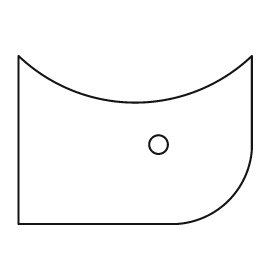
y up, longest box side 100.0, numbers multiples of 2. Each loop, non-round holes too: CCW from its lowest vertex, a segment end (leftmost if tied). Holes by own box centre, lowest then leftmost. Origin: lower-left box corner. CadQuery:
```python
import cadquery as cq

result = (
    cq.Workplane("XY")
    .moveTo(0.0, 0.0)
    .lineTo(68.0, 0.0)
    .threePointArc((90.0, 10.0), (100.0, 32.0))
    .lineTo(100.0, 72.0)
    .threePointArc((50.0, 52.0), (0.0, 72.0))
    .close()
    .moveTo(60.0, 34.0)
    .circle(4.0)
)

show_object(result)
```